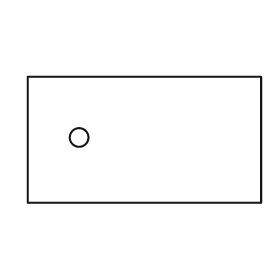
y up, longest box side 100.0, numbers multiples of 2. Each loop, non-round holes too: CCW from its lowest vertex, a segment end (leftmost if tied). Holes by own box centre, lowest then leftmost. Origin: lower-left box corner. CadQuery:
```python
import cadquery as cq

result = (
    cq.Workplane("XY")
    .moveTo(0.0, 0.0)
    .lineTo(100.0, 0.0)
    .lineTo(100.0, 54.0)
    .lineTo(0.0, 54.0)
    .close()
    .moveTo(22.0, 28.0)
    .circle(4.0)
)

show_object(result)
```